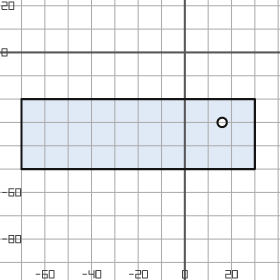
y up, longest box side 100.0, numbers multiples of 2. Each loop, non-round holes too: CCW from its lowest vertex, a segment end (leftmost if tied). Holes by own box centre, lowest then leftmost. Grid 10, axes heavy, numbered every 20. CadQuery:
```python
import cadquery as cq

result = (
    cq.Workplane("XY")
    .moveTo(-70.0, -50.0)
    .lineTo(30.0, -50.0)
    .lineTo(30.0, -20.0)
    .lineTo(-70.0, -20.0)
    .close()
    .moveTo(16.0, -30.0)
    .circle(2.0)
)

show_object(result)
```